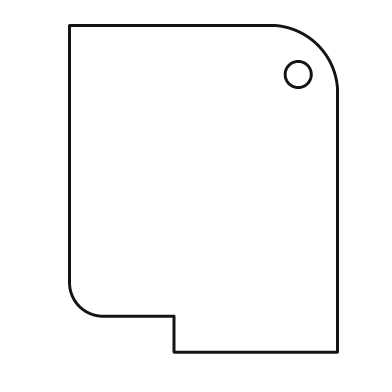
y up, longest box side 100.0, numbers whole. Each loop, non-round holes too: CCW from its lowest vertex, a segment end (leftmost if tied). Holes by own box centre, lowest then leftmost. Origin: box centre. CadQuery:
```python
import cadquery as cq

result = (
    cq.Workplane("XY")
    .moveTo(-9.0, -50.0)
    .lineTo(41.0, -50.0)
    .lineTo(41.0, 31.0)
    .threePointArc((35.0, 44.0), (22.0, 50.0))
    .lineTo(-41.0, 50.0)
    .lineTo(-41.0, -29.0)
    .threePointArc((-38.0, -36.0), (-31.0, -39.0))
    .lineTo(-9.0, -39.0)
    .close()
    .moveTo(29.0, 35.0)
    .circle(4.0)
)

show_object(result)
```